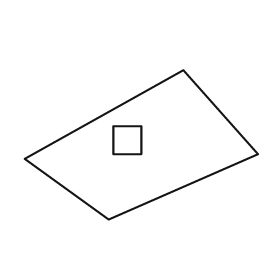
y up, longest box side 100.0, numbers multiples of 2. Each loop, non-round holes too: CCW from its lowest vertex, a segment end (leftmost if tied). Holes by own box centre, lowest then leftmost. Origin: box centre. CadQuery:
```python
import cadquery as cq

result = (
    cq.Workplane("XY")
    .moveTo(-14.0, -32.0)
    .lineTo(50.0, -4.0)
    .lineTo(18.0, 32.0)
    .lineTo(-50.0, -6.0)
    .close()
    .moveTo(-12.0, -4.0)
    .lineTo(0.0, -4.0)
    .lineTo(0.0, 8.0)
    .lineTo(-12.0, 8.0)
    .close()
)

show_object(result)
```